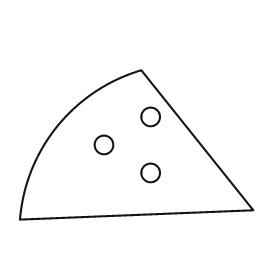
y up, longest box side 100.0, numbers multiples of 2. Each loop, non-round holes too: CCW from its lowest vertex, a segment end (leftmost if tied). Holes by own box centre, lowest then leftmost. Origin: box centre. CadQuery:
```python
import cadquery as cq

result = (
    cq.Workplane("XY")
    .moveTo(-50.0, -32.0)
    .lineTo(50.0, -28.0)
    .lineTo(2.0, 32.0)
    .threePointArc((-34.0, 8.0), (-50.0, -32.0))
    .close()
    .moveTo(6.0, -12.0)
    .circle(4.0)
    .moveTo(-14.0, 0.0)
    .circle(4.0)
    .moveTo(6.0, 12.0)
    .circle(4.0)
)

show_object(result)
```